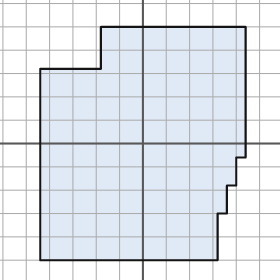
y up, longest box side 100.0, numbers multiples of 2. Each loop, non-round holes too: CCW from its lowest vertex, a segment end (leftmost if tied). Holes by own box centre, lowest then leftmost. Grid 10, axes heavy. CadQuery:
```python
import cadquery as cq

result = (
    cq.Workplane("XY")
    .moveTo(-44.0, -50.0)
    .lineTo(32.0, -50.0)
    .lineTo(32.0, -30.0)
    .lineTo(36.0, -30.0)
    .lineTo(36.0, -18.0)
    .lineTo(40.0, -18.0)
    .lineTo(40.0, -6.0)
    .lineTo(44.0, -6.0)
    .lineTo(44.0, 50.0)
    .lineTo(-18.0, 50.0)
    .lineTo(-18.0, 32.0)
    .lineTo(-44.0, 32.0)
    .close()
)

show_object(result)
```